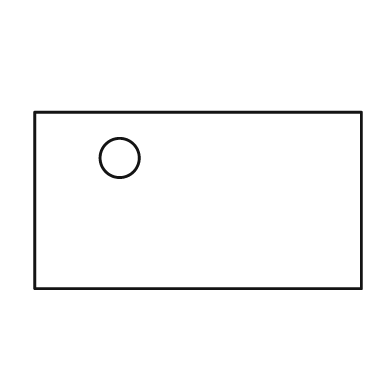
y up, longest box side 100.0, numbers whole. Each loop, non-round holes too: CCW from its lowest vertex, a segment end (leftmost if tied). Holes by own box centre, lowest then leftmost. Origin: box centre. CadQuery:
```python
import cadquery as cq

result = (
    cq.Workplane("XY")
    .moveTo(-50.0, -27.0)
    .lineTo(50.0, -27.0)
    .lineTo(50.0, 27.0)
    .lineTo(-50.0, 27.0)
    .close()
    .moveTo(-24.0, 13.0)
    .circle(6.0)
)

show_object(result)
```